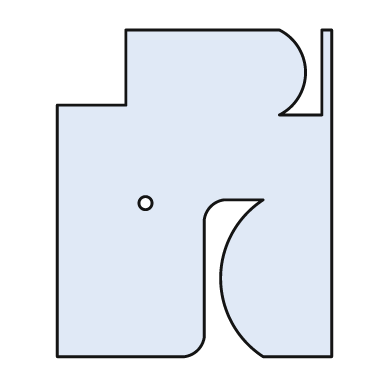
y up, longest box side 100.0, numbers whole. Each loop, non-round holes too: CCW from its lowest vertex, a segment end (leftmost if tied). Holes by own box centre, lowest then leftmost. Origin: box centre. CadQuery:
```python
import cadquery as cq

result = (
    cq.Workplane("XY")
    .moveTo(-42.0, -50.0)
    .lineTo(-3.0, -50.0)
    .threePointArc((1.0, -48.0), (3.0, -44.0))
    .lineTo(3.0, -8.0)
    .threePointArc((5.0, -4.0), (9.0, -2.0))
    .lineTo(21.0, -2.0)
    .threePointArc((8.0, -26.0), (21.0, -50.0))
    .lineTo(42.0, -50.0)
    .lineTo(42.0, 50.0)
    .lineTo(39.0, 50.0)
    .lineTo(39.0, 24.0)
    .lineTo(26.0, 24.0)
    .threePointArc((34.0, 37.0), (26.0, 50.0))
    .lineTo(-21.0, 50.0)
    .lineTo(-21.0, 27.0)
    .lineTo(-42.0, 27.0)
    .close()
    .moveTo(-15.0, -3.0)
    .circle(2.0)
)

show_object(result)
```